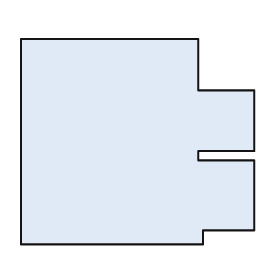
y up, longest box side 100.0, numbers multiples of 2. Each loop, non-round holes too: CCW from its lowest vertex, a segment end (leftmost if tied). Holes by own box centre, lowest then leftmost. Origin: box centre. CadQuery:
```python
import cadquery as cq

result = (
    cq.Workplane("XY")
    .moveTo(-50.0, -44.0)
    .lineTo(28.0, -44.0)
    .lineTo(28.0, -38.0)
    .lineTo(50.0, -38.0)
    .lineTo(50.0, -8.0)
    .lineTo(26.0, -8.0)
    .lineTo(26.0, -4.0)
    .lineTo(50.0, -4.0)
    .lineTo(50.0, 22.0)
    .lineTo(26.0, 22.0)
    .lineTo(26.0, 44.0)
    .lineTo(-50.0, 44.0)
    .close()
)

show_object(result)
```